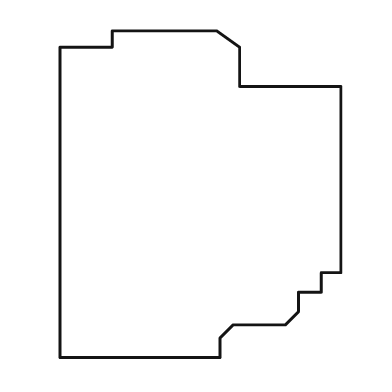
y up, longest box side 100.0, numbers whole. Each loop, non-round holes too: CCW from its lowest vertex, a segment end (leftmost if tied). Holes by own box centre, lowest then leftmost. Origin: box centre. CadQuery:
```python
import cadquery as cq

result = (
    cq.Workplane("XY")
    .moveTo(-43.0, -50.0)
    .lineTo(6.0, -50.0)
    .lineTo(6.0, -44.0)
    .lineTo(10.0, -40.0)
    .lineTo(26.0, -40.0)
    .lineTo(30.0, -36.0)
    .lineTo(30.0, -30.0)
    .lineTo(37.0, -30.0)
    .lineTo(37.0, -24.0)
    .lineTo(43.0, -24.0)
    .lineTo(43.0, 33.0)
    .lineTo(12.0, 33.0)
    .lineTo(12.0, 45.0)
    .lineTo(5.0, 50.0)
    .lineTo(-27.0, 50.0)
    .lineTo(-27.0, 45.0)
    .lineTo(-43.0, 45.0)
    .close()
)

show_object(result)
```